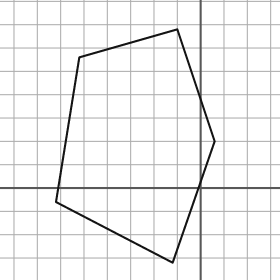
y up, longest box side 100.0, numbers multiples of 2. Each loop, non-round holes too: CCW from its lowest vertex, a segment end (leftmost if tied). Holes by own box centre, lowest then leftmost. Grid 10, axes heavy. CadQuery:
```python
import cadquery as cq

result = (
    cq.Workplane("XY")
    .moveTo(-12.0, -32.0)
    .lineTo(6.0, 20.0)
    .lineTo(-10.0, 68.0)
    .lineTo(-52.0, 56.0)
    .lineTo(-62.0, -6.0)
    .close()
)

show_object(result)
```